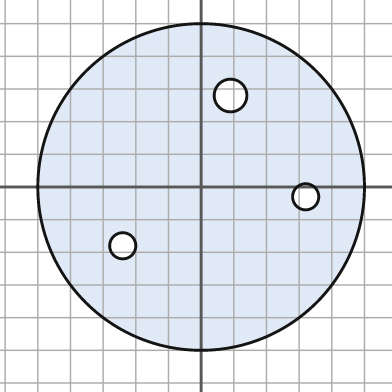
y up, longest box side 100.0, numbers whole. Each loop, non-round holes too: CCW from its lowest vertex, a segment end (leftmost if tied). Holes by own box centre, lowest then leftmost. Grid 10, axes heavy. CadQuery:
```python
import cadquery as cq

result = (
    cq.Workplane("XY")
    .moveTo(0.0, 0.0)
    .circle(50.0)
    .moveTo(-24.0, -18.0)
    .circle(4.0)
    .moveTo(32.0, -3.0)
    .circle(4.0)
    .moveTo(9.0, 28.0)
    .circle(5.0)
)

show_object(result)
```